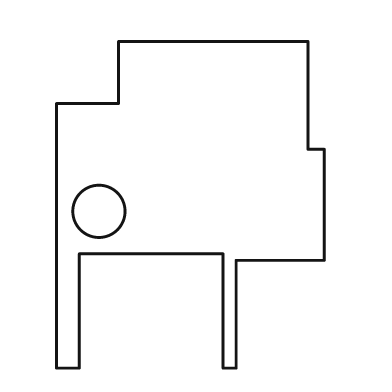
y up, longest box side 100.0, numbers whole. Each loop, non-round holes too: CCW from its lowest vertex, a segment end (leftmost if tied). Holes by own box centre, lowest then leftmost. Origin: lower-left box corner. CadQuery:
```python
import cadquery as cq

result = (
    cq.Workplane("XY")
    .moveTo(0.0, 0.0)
    .lineTo(7.0, 0.0)
    .lineTo(7.0, 35.0)
    .lineTo(51.0, 35.0)
    .lineTo(51.0, 0.0)
    .lineTo(55.0, 0.0)
    .lineTo(55.0, 33.0)
    .lineTo(82.0, 33.0)
    .lineTo(82.0, 67.0)
    .lineTo(77.0, 67.0)
    .lineTo(77.0, 100.0)
    .lineTo(19.0, 100.0)
    .lineTo(19.0, 81.0)
    .lineTo(0.0, 81.0)
    .close()
    .moveTo(13.0, 48.0)
    .circle(8.0)
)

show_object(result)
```